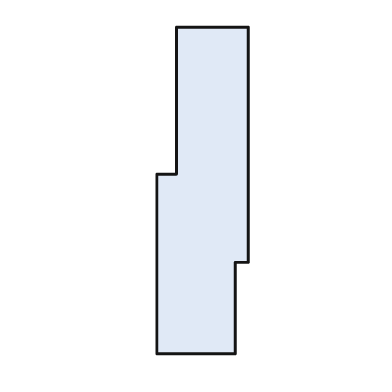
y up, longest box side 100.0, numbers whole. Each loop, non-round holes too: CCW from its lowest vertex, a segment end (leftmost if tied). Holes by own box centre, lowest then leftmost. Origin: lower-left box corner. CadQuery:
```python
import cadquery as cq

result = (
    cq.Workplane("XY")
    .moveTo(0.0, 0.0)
    .lineTo(24.0, 0.0)
    .lineTo(24.0, 28.0)
    .lineTo(28.0, 28.0)
    .lineTo(28.0, 100.0)
    .lineTo(6.0, 100.0)
    .lineTo(6.0, 55.0)
    .lineTo(0.0, 55.0)
    .close()
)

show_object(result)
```